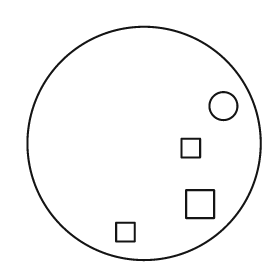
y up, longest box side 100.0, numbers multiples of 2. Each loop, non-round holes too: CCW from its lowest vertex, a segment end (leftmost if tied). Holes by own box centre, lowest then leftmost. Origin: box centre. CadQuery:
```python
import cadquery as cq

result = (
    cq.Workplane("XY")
    .moveTo(0.0, 0.0)
    .circle(50.0)
    .moveTo(-12.0, -42.0)
    .lineTo(-4.0, -42.0)
    .lineTo(-4.0, -34.0)
    .lineTo(-12.0, -34.0)
    .close()
    .moveTo(18.0, -32.0)
    .lineTo(30.0, -32.0)
    .lineTo(30.0, -20.0)
    .lineTo(18.0, -20.0)
    .close()
    .moveTo(16.0, -6.0)
    .lineTo(24.0, -6.0)
    .lineTo(24.0, 2.0)
    .lineTo(16.0, 2.0)
    .close()
    .moveTo(34.0, 16.0)
    .circle(6.0)
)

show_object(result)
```